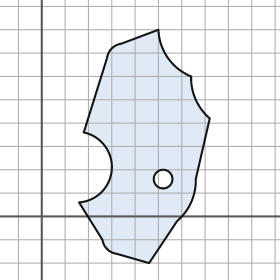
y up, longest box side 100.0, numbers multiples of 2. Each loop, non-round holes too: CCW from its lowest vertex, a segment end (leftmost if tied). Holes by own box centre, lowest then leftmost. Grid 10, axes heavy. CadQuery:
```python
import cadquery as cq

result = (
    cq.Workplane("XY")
    .moveTo(46.0, -20.0)
    .lineTo(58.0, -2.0)
    .threePointArc((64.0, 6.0), (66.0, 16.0))
    .lineTo(72.0, 42.0)
    .threePointArc((66.0, 50.0), (64.0, 60.0))
    .threePointArc((54.0, 68.0), (50.0, 80.0))
    .lineTo(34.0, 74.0)
    .threePointArc((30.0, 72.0), (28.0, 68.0))
    .lineTo(18.0, 36.0)
    .threePointArc((30.0, 20.0), (16.0, 6.0))
    .lineTo(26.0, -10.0)
    .threePointArc((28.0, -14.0), (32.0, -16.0))
    .close()
    .moveTo(52.0, 16.0)
    .circle(4.0)
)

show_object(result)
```